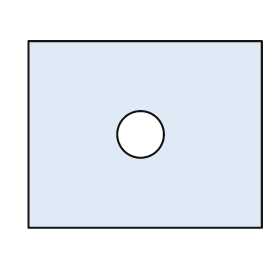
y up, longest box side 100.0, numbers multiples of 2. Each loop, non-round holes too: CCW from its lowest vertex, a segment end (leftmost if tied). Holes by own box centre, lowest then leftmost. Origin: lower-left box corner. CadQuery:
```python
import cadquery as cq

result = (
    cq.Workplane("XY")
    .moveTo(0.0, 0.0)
    .lineTo(100.0, 0.0)
    .lineTo(100.0, 80.0)
    .lineTo(0.0, 80.0)
    .close()
    .moveTo(48.0, 40.0)
    .circle(10.0)
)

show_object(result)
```